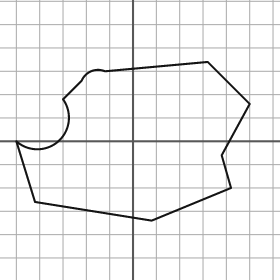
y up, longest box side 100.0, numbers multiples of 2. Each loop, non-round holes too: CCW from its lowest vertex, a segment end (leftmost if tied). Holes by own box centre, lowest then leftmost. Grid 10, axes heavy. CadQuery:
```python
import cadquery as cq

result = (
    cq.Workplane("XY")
    .moveTo(8.0, -34.0)
    .lineTo(42.0, -20.0)
    .lineTo(38.0, -6.0)
    .lineTo(50.0, 16.0)
    .lineTo(32.0, 34.0)
    .lineTo(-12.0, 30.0)
    .threePointArc((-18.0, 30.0), (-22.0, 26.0))
    .lineTo(-30.0, 18.0)
    .threePointArc((-32.0, 0.0), (-50.0, 0.0))
    .lineTo(-42.0, -26.0)
    .close()
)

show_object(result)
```